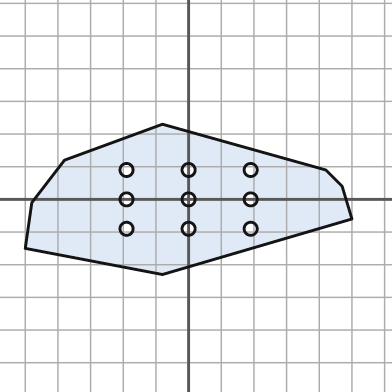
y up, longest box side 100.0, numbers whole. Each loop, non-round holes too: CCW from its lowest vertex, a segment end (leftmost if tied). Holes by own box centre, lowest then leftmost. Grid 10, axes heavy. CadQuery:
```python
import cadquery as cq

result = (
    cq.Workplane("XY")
    .moveTo(-8.0, -23.0)
    .lineTo(50.0, -6.0)
    .lineTo(47.0, 4.0)
    .lineTo(42.0, 9.0)
    .lineTo(-8.0, 23.0)
    .lineTo(-38.0, 12.0)
    .lineTo(-48.0, -1.0)
    .lineTo(-50.0, -15.0)
    .close()
    .moveTo(-19.0, -9.0)
    .circle(2.0)
    .moveTo(0.0, -9.0)
    .circle(2.0)
    .moveTo(19.0, -9.0)
    .circle(2.0)
    .moveTo(-19.0, 0.0)
    .circle(2.0)
    .moveTo(0.0, 0.0)
    .circle(2.0)
    .moveTo(19.0, 0.0)
    .circle(2.0)
    .moveTo(-19.0, 9.0)
    .circle(2.0)
    .moveTo(0.0, 9.0)
    .circle(2.0)
    .moveTo(19.0, 9.0)
    .circle(2.0)
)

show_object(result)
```